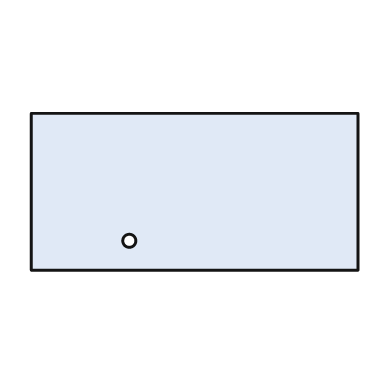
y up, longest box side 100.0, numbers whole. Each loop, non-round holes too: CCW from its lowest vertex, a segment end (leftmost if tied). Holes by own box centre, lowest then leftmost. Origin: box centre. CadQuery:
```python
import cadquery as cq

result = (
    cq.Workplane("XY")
    .moveTo(-50.0, -24.0)
    .lineTo(50.0, -24.0)
    .lineTo(50.0, 24.0)
    .lineTo(-50.0, 24.0)
    .close()
    .moveTo(-20.0, -15.0)
    .circle(2.0)
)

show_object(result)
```